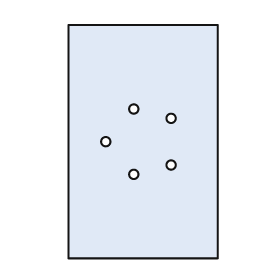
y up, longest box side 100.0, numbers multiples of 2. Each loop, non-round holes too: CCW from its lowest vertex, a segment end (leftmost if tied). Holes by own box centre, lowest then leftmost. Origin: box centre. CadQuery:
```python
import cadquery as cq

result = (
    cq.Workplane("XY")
    .moveTo(-32.0, -50.0)
    .lineTo(32.0, -50.0)
    .lineTo(32.0, 50.0)
    .lineTo(-32.0, 50.0)
    .close()
    .moveTo(-4.0, -14.0)
    .circle(2.0)
    .moveTo(12.0, -10.0)
    .circle(2.0)
    .moveTo(-16.0, 0.0)
    .circle(2.0)
    .moveTo(12.0, 10.0)
    .circle(2.0)
    .moveTo(-4.0, 14.0)
    .circle(2.0)
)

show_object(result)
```